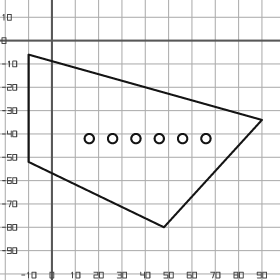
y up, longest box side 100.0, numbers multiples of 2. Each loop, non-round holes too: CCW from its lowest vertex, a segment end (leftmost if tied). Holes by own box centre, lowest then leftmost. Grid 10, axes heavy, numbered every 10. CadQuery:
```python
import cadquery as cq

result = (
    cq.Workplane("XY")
    .moveTo(48.0, -80.0)
    .lineTo(90.0, -34.0)
    .lineTo(-10.0, -6.0)
    .lineTo(-10.0, -52.0)
    .close()
    .moveTo(16.0, -42.0)
    .circle(2.0)
    .moveTo(26.0, -42.0)
    .circle(2.0)
    .moveTo(36.0, -42.0)
    .circle(2.0)
    .moveTo(46.0, -42.0)
    .circle(2.0)
    .moveTo(56.0, -42.0)
    .circle(2.0)
    .moveTo(66.0, -42.0)
    .circle(2.0)
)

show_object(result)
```